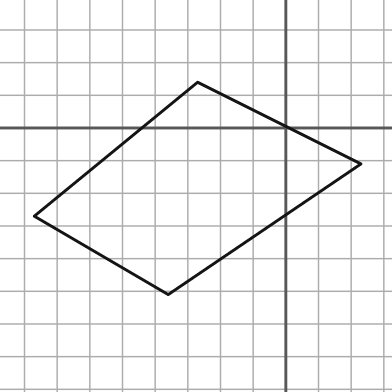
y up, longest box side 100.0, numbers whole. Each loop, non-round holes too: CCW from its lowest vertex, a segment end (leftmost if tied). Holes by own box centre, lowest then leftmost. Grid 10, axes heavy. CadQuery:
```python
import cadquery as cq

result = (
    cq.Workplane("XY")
    .moveTo(-36.0, -51.0)
    .lineTo(23.0, -11.0)
    .lineTo(-27.0, 14.0)
    .lineTo(-77.0, -27.0)
    .close()
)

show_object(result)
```